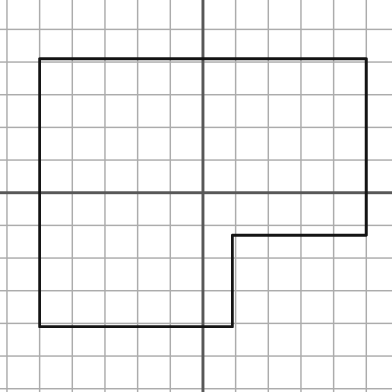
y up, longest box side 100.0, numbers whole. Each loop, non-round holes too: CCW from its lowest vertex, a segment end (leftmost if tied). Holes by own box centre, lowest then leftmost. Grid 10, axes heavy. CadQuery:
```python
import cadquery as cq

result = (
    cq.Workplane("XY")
    .moveTo(-50.0, -41.0)
    .lineTo(9.0, -41.0)
    .lineTo(9.0, -13.0)
    .lineTo(50.0, -13.0)
    .lineTo(50.0, 41.0)
    .lineTo(-50.0, 41.0)
    .close()
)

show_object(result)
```